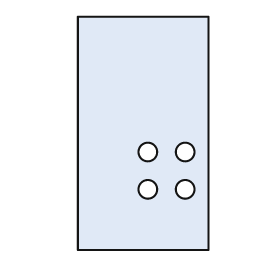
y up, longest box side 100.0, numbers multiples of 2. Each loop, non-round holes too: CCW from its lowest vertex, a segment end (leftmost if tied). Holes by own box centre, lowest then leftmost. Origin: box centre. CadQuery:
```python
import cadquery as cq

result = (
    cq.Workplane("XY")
    .moveTo(-28.0, -50.0)
    .lineTo(28.0, -50.0)
    .lineTo(28.0, 50.0)
    .lineTo(-28.0, 50.0)
    .close()
    .moveTo(2.0, -24.0)
    .circle(4.0)
    .moveTo(18.0, -24.0)
    .circle(4.0)
    .moveTo(2.0, -8.0)
    .circle(4.0)
    .moveTo(18.0, -8.0)
    .circle(4.0)
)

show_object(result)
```